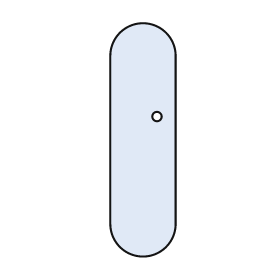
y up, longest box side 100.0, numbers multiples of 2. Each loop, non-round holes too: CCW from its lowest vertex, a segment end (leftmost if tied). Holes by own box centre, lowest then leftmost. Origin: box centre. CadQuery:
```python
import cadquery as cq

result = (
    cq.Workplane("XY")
    .moveTo(-14.0, -36.0)
    .threePointArc((0.0, -50.0), (14.0, -36.0))
    .lineTo(14.0, 36.0)
    .threePointArc((0.0, 50.0), (-14.0, 36.0))
    .close()
    .moveTo(6.0, 10.0)
    .circle(2.0)
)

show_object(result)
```